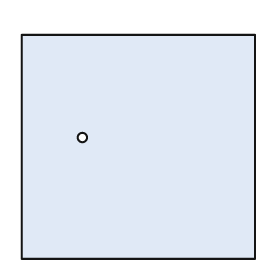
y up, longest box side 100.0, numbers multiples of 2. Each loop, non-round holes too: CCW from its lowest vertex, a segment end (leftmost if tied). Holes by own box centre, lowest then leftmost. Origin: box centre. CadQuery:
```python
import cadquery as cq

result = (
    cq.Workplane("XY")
    .moveTo(-50.0, -48.0)
    .lineTo(50.0, -48.0)
    .lineTo(50.0, 48.0)
    .lineTo(-50.0, 48.0)
    .close()
    .moveTo(-24.0, 4.0)
    .circle(2.0)
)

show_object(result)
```